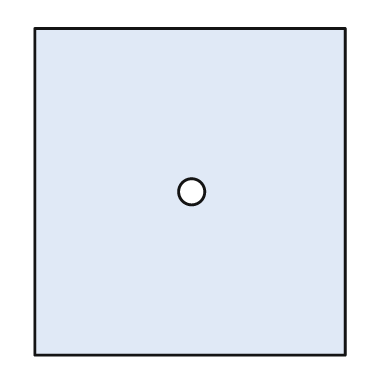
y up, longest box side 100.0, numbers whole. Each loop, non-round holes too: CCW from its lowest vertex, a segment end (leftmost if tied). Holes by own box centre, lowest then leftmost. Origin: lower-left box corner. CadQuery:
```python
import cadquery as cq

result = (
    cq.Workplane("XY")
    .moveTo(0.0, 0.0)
    .lineTo(95.0, 0.0)
    .lineTo(95.0, 100.0)
    .lineTo(0.0, 100.0)
    .close()
    .moveTo(48.0, 50.0)
    .circle(4.0)
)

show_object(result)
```